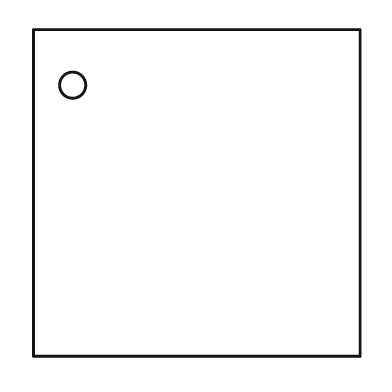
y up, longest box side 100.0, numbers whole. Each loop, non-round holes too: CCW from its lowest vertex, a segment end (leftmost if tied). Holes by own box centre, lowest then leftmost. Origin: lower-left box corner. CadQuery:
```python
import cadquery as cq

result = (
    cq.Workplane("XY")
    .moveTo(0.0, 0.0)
    .lineTo(100.0, 0.0)
    .lineTo(100.0, 100.0)
    .lineTo(0.0, 100.0)
    .close()
    .moveTo(12.0, 83.0)
    .circle(4.0)
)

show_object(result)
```